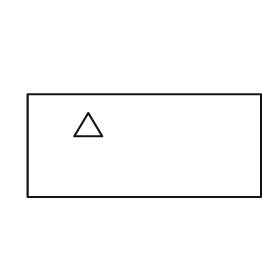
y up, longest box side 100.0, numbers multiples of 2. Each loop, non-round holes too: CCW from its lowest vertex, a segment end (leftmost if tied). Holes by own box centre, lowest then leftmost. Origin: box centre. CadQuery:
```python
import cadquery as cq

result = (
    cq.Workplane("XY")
    .moveTo(-50.0, -22.0)
    .lineTo(50.0, -22.0)
    .lineTo(50.0, 22.0)
    .lineTo(-50.0, 22.0)
    .close()
    .moveTo(-30.0, 4.0)
    .lineTo(-18.0, 4.0)
    .lineTo(-24.0, 14.0)
    .close()
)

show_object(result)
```